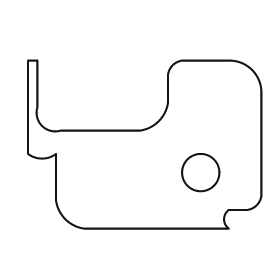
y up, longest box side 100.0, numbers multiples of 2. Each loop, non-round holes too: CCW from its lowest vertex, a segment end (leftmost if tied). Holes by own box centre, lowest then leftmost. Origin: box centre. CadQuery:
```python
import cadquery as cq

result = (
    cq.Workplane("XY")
    .moveTo(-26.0, -36.0)
    .lineTo(36.0, -36.0)
    .threePointArc((34.0, -32.0), (36.0, -28.0))
    .lineTo(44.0, -28.0)
    .threePointArc((48.0, -26.0), (50.0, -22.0))
    .lineTo(50.0, 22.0)
    .threePointArc((46.0, 32.0), (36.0, 36.0))
    .lineTo(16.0, 36.0)
    .threePointArc((12.0, 34.0), (10.0, 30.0))
    .lineTo(10.0, 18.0)
    .threePointArc((6.0, 10.0), (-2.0, 6.0))
    .lineTo(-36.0, 6.0)
    .threePointArc((-44.0, 8.0), (-46.0, 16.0))
    .lineTo(-46.0, 36.0)
    .lineTo(-50.0, 36.0)
    .lineTo(-50.0, -4.0)
    .threePointArc((-44.0, -6.0), (-38.0, -4.0))
    .lineTo(-38.0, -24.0)
    .threePointArc((-34.0, -32.0), (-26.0, -36.0))
    .close()
    .moveTo(24.0, -12.0)
    .circle(8.0)
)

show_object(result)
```